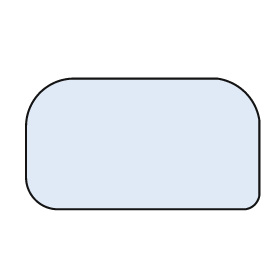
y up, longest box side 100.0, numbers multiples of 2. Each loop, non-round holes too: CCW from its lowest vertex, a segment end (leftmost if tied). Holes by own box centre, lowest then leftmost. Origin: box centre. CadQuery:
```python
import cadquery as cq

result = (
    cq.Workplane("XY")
    .moveTo(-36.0, -28.0)
    .lineTo(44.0, -28.0)
    .threePointArc((48.0, -26.0), (50.0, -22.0))
    .lineTo(50.0, 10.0)
    .threePointArc((44.0, 22.0), (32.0, 28.0))
    .lineTo(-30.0, 28.0)
    .threePointArc((-44.0, 22.0), (-50.0, 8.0))
    .lineTo(-50.0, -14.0)
    .threePointArc((-46.0, -24.0), (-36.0, -28.0))
    .close()
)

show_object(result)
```